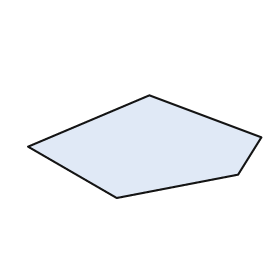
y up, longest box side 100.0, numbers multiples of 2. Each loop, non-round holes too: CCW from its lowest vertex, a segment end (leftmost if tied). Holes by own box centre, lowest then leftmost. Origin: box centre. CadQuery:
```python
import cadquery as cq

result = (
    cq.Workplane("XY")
    .moveTo(-12.0, -22.0)
    .lineTo(40.0, -12.0)
    .lineTo(50.0, 4.0)
    .lineTo(2.0, 22.0)
    .lineTo(-50.0, 0.0)
    .close()
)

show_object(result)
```